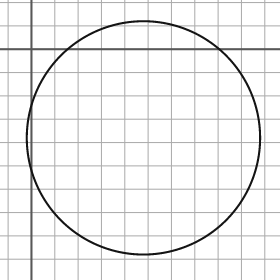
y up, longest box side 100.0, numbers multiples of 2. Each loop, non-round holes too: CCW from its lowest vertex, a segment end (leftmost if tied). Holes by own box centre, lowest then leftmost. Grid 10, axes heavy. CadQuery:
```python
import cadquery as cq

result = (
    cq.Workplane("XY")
    .moveTo(48.0, -38.0)
    .circle(50.0)
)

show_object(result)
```